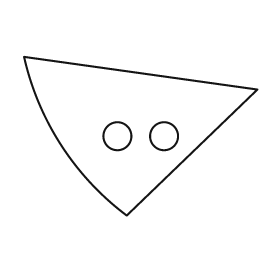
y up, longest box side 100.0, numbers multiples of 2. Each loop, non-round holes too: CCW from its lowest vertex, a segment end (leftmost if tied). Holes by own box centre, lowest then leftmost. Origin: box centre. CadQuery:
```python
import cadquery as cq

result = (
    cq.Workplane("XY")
    .moveTo(-6.0, -34.0)
    .lineTo(50.0, 20.0)
    .lineTo(-50.0, 34.0)
    .threePointArc((-34.0, -4.0), (-6.0, -34.0))
    .close()
    .moveTo(-10.0, 0.0)
    .circle(6.0)
    .moveTo(10.0, 0.0)
    .circle(6.0)
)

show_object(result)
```